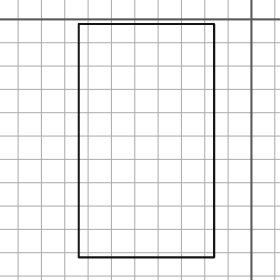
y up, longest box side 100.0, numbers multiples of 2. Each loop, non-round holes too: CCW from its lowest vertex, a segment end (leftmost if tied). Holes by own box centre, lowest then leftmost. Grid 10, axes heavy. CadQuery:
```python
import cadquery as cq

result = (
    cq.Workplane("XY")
    .moveTo(-74.0, -102.0)
    .lineTo(-16.0, -102.0)
    .lineTo(-16.0, -2.0)
    .lineTo(-74.0, -2.0)
    .close()
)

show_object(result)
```